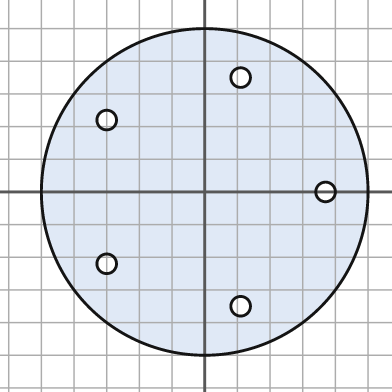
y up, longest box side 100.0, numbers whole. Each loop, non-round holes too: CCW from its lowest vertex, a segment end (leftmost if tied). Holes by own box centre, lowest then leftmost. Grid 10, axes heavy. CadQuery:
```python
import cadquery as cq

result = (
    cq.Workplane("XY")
    .moveTo(0.0, 0.0)
    .circle(50.0)
    .moveTo(11.0, -35.0)
    .circle(3.0)
    .moveTo(-30.0, -22.0)
    .circle(3.0)
    .moveTo(37.0, 0.0)
    .circle(3.0)
    .moveTo(-30.0, 22.0)
    .circle(3.0)
    .moveTo(11.0, 35.0)
    .circle(3.0)
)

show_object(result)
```